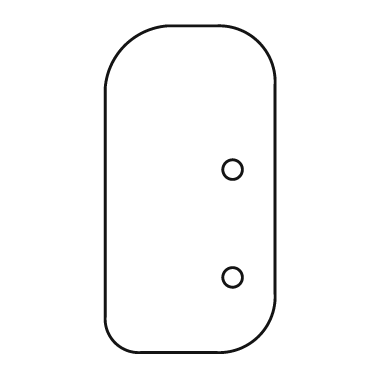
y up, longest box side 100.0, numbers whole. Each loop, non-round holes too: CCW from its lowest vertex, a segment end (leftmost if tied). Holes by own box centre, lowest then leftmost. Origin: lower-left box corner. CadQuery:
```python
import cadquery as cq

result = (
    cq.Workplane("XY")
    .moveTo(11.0, 0.0)
    .lineTo(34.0, 0.0)
    .threePointArc((47.0, 5.0), (52.0, 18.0))
    .lineTo(52.0, 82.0)
    .threePointArc((47.0, 95.0), (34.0, 100.0))
    .lineTo(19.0, 100.0)
    .threePointArc((6.0, 94.0), (0.0, 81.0))
    .lineTo(0.0, 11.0)
    .threePointArc((3.0, 3.0), (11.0, 0.0))
    .close()
    .moveTo(39.0, 23.0)
    .circle(3.0)
    .moveTo(39.0, 56.0)
    .circle(3.0)
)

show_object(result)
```